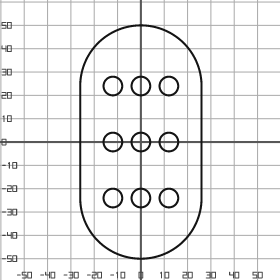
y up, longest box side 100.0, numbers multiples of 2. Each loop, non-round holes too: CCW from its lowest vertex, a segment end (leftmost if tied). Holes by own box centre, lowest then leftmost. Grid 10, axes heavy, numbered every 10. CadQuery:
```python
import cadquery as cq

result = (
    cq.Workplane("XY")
    .moveTo(-26.0, -24.0)
    .threePointArc((0.0, -50.0), (26.0, -24.0))
    .lineTo(26.0, 24.0)
    .threePointArc((0.0, 50.0), (-26.0, 24.0))
    .close()
    .moveTo(-12.0, -24.0)
    .circle(4.0)
    .moveTo(0.0, -24.0)
    .circle(4.0)
    .moveTo(12.0, -24.0)
    .circle(4.0)
    .moveTo(-12.0, 0.0)
    .circle(4.0)
    .moveTo(0.0, 0.0)
    .circle(4.0)
    .moveTo(12.0, 0.0)
    .circle(4.0)
    .moveTo(-12.0, 24.0)
    .circle(4.0)
    .moveTo(0.0, 24.0)
    .circle(4.0)
    .moveTo(12.0, 24.0)
    .circle(4.0)
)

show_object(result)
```